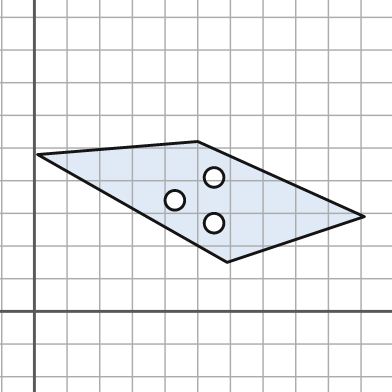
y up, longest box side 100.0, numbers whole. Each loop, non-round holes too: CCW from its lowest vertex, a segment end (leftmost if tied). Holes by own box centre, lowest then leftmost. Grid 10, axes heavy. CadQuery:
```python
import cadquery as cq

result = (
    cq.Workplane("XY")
    .moveTo(59.0, 15.0)
    .lineTo(101.0, 29.0)
    .lineTo(50.0, 52.0)
    .lineTo(1.0, 48.0)
    .close()
    .moveTo(55.0, 27.0)
    .circle(3.0)
    .moveTo(43.0, 34.0)
    .circle(3.0)
    .moveTo(55.0, 41.0)
    .circle(3.0)
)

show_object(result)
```